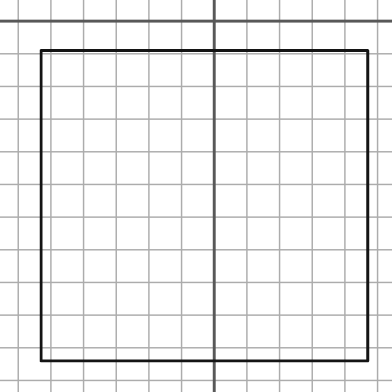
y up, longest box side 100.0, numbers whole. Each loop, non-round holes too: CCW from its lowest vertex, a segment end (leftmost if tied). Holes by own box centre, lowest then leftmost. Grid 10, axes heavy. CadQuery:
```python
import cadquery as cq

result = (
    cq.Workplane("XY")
    .moveTo(-53.0, -104.0)
    .lineTo(47.0, -104.0)
    .lineTo(47.0, -9.0)
    .lineTo(-53.0, -9.0)
    .close()
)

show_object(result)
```